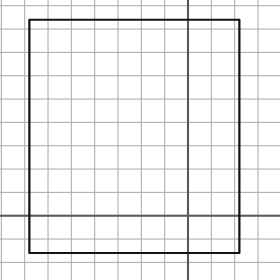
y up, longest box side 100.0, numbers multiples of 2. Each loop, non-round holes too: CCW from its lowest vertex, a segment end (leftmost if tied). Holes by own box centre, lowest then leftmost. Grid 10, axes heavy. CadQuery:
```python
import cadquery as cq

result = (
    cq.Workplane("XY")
    .moveTo(-68.0, -16.0)
    .lineTo(22.0, -16.0)
    .lineTo(22.0, 84.0)
    .lineTo(-68.0, 84.0)
    .close()
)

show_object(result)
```